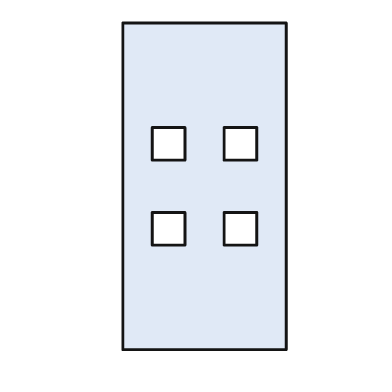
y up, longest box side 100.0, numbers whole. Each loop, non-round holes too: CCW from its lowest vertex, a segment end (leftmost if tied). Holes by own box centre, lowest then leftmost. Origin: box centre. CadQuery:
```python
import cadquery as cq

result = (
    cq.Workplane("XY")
    .moveTo(-25.0, -50.0)
    .lineTo(25.0, -50.0)
    .lineTo(25.0, 50.0)
    .lineTo(-25.0, 50.0)
    .close()
    .moveTo(-16.0, -18.0)
    .lineTo(-6.0, -18.0)
    .lineTo(-6.0, -8.0)
    .lineTo(-16.0, -8.0)
    .close()
    .moveTo(6.0, -18.0)
    .lineTo(16.0, -18.0)
    .lineTo(16.0, -8.0)
    .lineTo(6.0, -8.0)
    .close()
    .moveTo(-16.0, 8.0)
    .lineTo(-6.0, 8.0)
    .lineTo(-6.0, 18.0)
    .lineTo(-16.0, 18.0)
    .close()
    .moveTo(6.0, 8.0)
    .lineTo(16.0, 8.0)
    .lineTo(16.0, 18.0)
    .lineTo(6.0, 18.0)
    .close()
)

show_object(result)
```